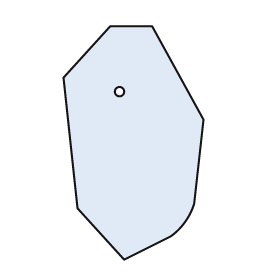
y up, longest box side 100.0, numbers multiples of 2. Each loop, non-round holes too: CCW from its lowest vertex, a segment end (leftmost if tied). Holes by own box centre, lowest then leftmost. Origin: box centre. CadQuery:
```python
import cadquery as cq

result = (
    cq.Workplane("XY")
    .moveTo(-4.0, -50.0)
    .lineTo(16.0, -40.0)
    .threePointArc((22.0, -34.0), (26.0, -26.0))
    .lineTo(30.0, 10.0)
    .lineTo(8.0, 50.0)
    .lineTo(-10.0, 50.0)
    .lineTo(-30.0, 28.0)
    .lineTo(-24.0, -28.0)
    .close()
    .moveTo(-6.0, 22.0)
    .circle(2.0)
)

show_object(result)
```